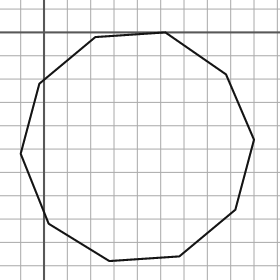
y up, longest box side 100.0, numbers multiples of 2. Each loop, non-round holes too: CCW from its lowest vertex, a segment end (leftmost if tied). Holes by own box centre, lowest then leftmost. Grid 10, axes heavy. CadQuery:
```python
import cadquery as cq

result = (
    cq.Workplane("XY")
    .moveTo(28.0, -98.0)
    .lineTo(58.0, -96.0)
    .lineTo(82.0, -76.0)
    .lineTo(90.0, -46.0)
    .lineTo(78.0, -18.0)
    .lineTo(52.0, 0.0)
    .lineTo(22.0, -2.0)
    .lineTo(-2.0, -22.0)
    .lineTo(-10.0, -52.0)
    .lineTo(2.0, -82.0)
    .close()
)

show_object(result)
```